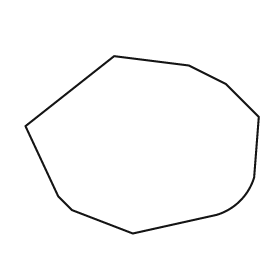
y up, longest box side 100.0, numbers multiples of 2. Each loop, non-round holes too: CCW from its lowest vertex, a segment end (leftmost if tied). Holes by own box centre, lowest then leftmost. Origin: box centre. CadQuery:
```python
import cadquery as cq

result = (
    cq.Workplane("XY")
    .moveTo(-4.0, -38.0)
    .lineTo(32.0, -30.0)
    .threePointArc((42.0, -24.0), (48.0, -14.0))
    .lineTo(50.0, 12.0)
    .lineTo(36.0, 26.0)
    .lineTo(20.0, 34.0)
    .lineTo(-12.0, 38.0)
    .lineTo(-50.0, 8.0)
    .lineTo(-36.0, -22.0)
    .lineTo(-30.0, -28.0)
    .close()
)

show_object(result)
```